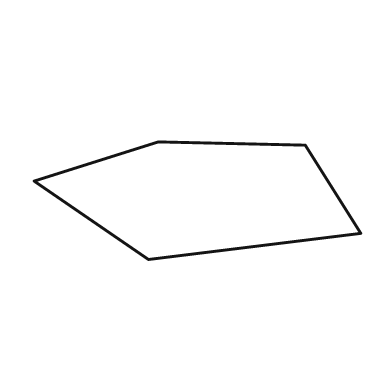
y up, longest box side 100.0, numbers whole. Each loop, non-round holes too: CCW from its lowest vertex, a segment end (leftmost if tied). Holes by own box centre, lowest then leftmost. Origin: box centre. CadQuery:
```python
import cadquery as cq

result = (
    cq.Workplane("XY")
    .moveTo(-15.0, -18.0)
    .lineTo(50.0, -10.0)
    .lineTo(33.0, 17.0)
    .lineTo(-12.0, 18.0)
    .lineTo(-50.0, 6.0)
    .close()
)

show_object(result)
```